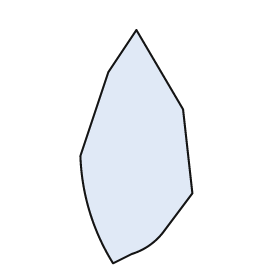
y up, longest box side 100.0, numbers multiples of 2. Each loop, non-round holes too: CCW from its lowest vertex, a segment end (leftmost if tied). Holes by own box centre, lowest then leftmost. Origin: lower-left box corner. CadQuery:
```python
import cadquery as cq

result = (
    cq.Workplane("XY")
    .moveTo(14.0, 0.0)
    .lineTo(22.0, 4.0)
    .threePointArc((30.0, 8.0), (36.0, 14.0))
    .lineTo(48.0, 30.0)
    .lineTo(44.0, 66.0)
    .lineTo(24.0, 100.0)
    .lineTo(12.0, 82.0)
    .lineTo(0.0, 46.0)
    .threePointArc((4.0, 22.0), (14.0, 0.0))
    .close()
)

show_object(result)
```